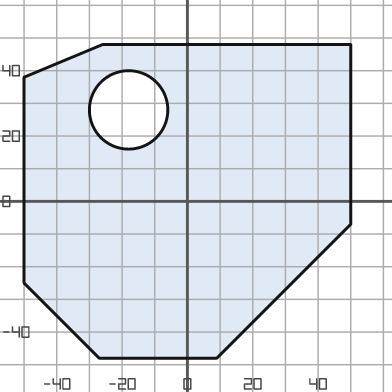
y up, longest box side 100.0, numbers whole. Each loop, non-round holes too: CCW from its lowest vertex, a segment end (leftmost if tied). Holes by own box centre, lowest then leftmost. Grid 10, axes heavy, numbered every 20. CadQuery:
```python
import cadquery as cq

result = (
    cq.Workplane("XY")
    .moveTo(-27.0, -48.0)
    .lineTo(9.0, -48.0)
    .lineTo(50.0, -7.0)
    .lineTo(50.0, 48.0)
    .lineTo(-26.0, 48.0)
    .lineTo(-50.0, 38.0)
    .lineTo(-50.0, -25.0)
    .close()
    .moveTo(-18.0, 28.0)
    .circle(12.0)
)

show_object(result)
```